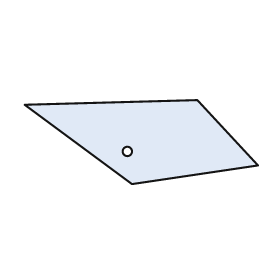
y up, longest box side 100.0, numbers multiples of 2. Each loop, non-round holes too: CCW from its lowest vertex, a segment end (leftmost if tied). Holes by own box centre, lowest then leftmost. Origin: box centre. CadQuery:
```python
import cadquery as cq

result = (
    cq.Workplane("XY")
    .moveTo(-4.0, -18.0)
    .lineTo(50.0, -10.0)
    .lineTo(24.0, 18.0)
    .lineTo(-50.0, 16.0)
    .close()
    .moveTo(-6.0, -4.0)
    .circle(2.0)
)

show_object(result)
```